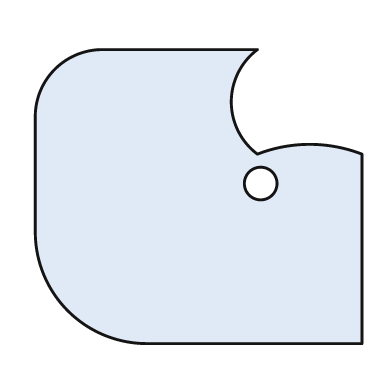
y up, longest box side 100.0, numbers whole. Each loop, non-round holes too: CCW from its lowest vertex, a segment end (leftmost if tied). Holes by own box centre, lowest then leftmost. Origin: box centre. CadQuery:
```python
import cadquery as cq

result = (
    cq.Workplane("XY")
    .moveTo(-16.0, -45.0)
    .lineTo(50.0, -45.0)
    .lineTo(50.0, 13.0)
    .threePointArc((34.0, 16.0), (18.0, 13.0))
    .threePointArc((10.0, 29.0), (18.0, 45.0))
    .lineTo(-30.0, 45.0)
    .threePointArc((-44.0, 39.0), (-50.0, 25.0))
    .lineTo(-50.0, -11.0)
    .threePointArc((-40.0, -35.0), (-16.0, -45.0))
    .close()
    .moveTo(19.0, 4.0)
    .circle(5.0)
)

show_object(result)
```